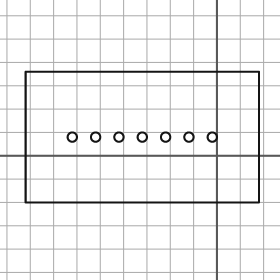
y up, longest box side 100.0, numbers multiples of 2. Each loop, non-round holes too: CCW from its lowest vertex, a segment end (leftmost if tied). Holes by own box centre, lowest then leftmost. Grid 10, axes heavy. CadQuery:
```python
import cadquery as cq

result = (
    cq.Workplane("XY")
    .moveTo(-82.0, -20.0)
    .lineTo(18.0, -20.0)
    .lineTo(18.0, 36.0)
    .lineTo(-82.0, 36.0)
    .close()
    .moveTo(-62.0, 8.0)
    .circle(2.0)
    .moveTo(-52.0, 8.0)
    .circle(2.0)
    .moveTo(-42.0, 8.0)
    .circle(2.0)
    .moveTo(-32.0, 8.0)
    .circle(2.0)
    .moveTo(-22.0, 8.0)
    .circle(2.0)
    .moveTo(-12.0, 8.0)
    .circle(2.0)
    .moveTo(-2.0, 8.0)
    .circle(2.0)
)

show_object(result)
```